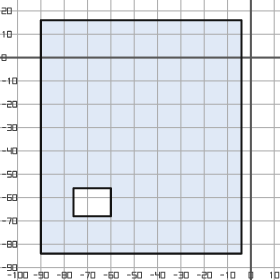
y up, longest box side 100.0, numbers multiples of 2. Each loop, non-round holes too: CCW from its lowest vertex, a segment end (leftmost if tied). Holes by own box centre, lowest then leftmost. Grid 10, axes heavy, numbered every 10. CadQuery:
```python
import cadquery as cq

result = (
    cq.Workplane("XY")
    .moveTo(-90.0, -84.0)
    .lineTo(-4.0, -84.0)
    .lineTo(-4.0, 16.0)
    .lineTo(-90.0, 16.0)
    .close()
    .moveTo(-76.0, -68.0)
    .lineTo(-60.0, -68.0)
    .lineTo(-60.0, -56.0)
    .lineTo(-76.0, -56.0)
    .close()
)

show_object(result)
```